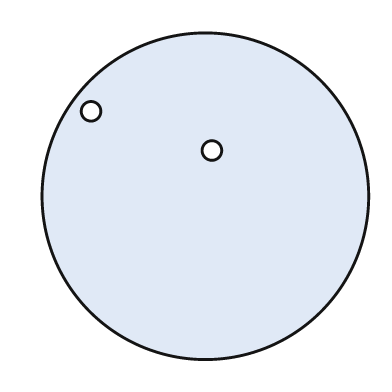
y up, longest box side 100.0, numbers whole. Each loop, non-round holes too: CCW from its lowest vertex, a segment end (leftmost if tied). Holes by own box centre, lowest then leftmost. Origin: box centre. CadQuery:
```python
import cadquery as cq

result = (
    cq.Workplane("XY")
    .moveTo(0.0, 0.0)
    .circle(50.0)
    .moveTo(2.0, 14.0)
    .circle(3.0)
    .moveTo(-35.0, 26.0)
    .circle(3.0)
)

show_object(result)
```